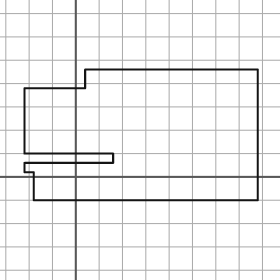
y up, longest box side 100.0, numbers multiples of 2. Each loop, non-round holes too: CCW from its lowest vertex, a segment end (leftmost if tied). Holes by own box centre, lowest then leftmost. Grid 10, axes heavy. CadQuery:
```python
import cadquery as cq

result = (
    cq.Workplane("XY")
    .moveTo(-18.0, -10.0)
    .lineTo(78.0, -10.0)
    .lineTo(78.0, 46.0)
    .lineTo(4.0, 46.0)
    .lineTo(4.0, 38.0)
    .lineTo(-22.0, 38.0)
    .lineTo(-22.0, 10.0)
    .lineTo(16.0, 10.0)
    .lineTo(16.0, 6.0)
    .lineTo(-22.0, 6.0)
    .lineTo(-22.0, 2.0)
    .lineTo(-18.0, 2.0)
    .close()
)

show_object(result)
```